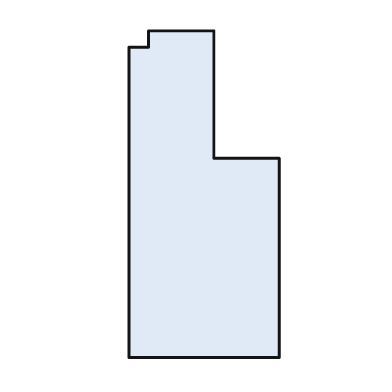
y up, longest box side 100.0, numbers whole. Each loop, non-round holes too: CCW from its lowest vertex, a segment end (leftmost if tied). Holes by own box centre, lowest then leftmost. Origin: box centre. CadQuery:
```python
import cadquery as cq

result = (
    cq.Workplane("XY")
    .moveTo(-23.0, -50.0)
    .lineTo(23.0, -50.0)
    .lineTo(23.0, 11.0)
    .lineTo(3.0, 11.0)
    .lineTo(3.0, 50.0)
    .lineTo(-17.0, 50.0)
    .lineTo(-17.0, 45.0)
    .lineTo(-23.0, 45.0)
    .close()
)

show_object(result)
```